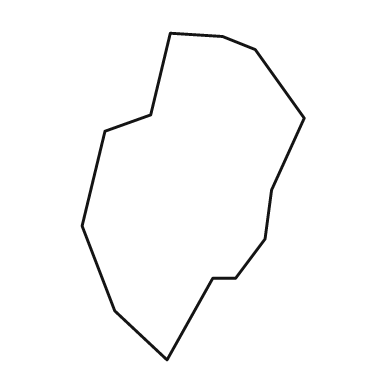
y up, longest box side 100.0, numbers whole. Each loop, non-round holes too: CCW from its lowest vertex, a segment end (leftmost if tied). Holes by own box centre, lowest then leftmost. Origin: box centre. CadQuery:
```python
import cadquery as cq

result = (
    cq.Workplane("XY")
    .moveTo(-8.0, -50.0)
    .lineTo(6.0, -25.0)
    .lineTo(13.0, -25.0)
    .lineTo(22.0, -13.0)
    .lineTo(24.0, 2.0)
    .lineTo(34.0, 24.0)
    .lineTo(19.0, 45.0)
    .lineTo(9.0, 49.0)
    .lineTo(-7.0, 50.0)
    .lineTo(-13.0, 25.0)
    .lineTo(-27.0, 20.0)
    .lineTo(-34.0, -9.0)
    .lineTo(-24.0, -35.0)
    .close()
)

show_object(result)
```